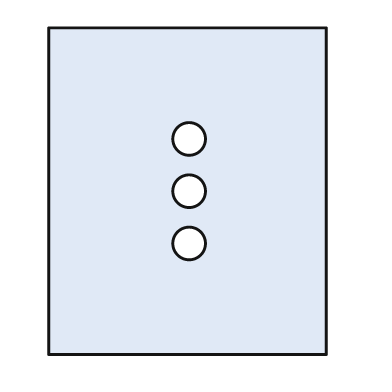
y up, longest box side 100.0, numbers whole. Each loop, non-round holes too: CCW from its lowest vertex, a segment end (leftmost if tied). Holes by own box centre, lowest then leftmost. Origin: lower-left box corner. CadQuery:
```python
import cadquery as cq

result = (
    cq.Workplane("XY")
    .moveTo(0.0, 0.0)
    .lineTo(85.0, 0.0)
    .lineTo(85.0, 100.0)
    .lineTo(0.0, 100.0)
    .close()
    .moveTo(43.0, 34.0)
    .circle(5.0)
    .moveTo(43.0, 50.0)
    .circle(5.0)
    .moveTo(43.0, 66.0)
    .circle(5.0)
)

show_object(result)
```